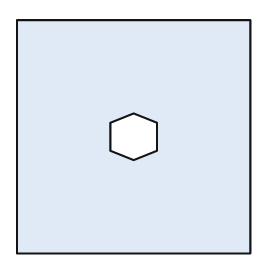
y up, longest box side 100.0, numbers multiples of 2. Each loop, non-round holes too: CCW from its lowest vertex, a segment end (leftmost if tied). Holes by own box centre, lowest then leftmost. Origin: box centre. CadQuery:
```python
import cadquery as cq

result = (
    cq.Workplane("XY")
    .moveTo(-50.0, -50.0)
    .lineTo(50.0, -50.0)
    .lineTo(50.0, 50.0)
    .lineTo(-50.0, 50.0)
    .close()
    .moveTo(0.0, -10.0)
    .lineTo(10.0, -6.0)
    .lineTo(10.0, 6.0)
    .lineTo(0.0, 10.0)
    .lineTo(-10.0, 6.0)
    .lineTo(-10.0, -6.0)
    .close()
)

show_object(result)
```